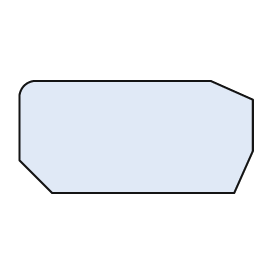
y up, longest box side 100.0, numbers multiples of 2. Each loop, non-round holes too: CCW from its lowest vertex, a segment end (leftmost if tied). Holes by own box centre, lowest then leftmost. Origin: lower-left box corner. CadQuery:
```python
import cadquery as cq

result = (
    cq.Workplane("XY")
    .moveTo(14.0, 0.0)
    .lineTo(92.0, 0.0)
    .lineTo(100.0, 18.0)
    .lineTo(100.0, 40.0)
    .lineTo(82.0, 48.0)
    .lineTo(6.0, 48.0)
    .threePointArc((2.0, 46.0), (0.0, 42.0))
    .lineTo(0.0, 14.0)
    .close()
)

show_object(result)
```